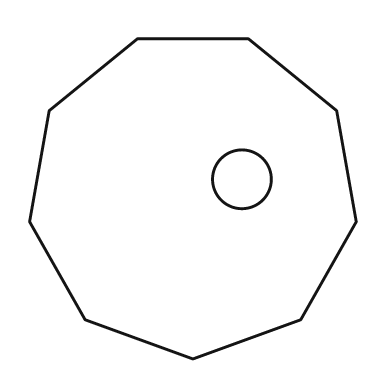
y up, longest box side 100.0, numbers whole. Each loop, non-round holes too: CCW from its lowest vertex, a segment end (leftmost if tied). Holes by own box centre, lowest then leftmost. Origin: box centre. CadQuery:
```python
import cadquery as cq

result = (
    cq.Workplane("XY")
    .moveTo(0.0, -49.0)
    .lineTo(33.0, -37.0)
    .lineTo(50.0, -7.0)
    .lineTo(44.0, 27.0)
    .lineTo(17.0, 49.0)
    .lineTo(-17.0, 49.0)
    .lineTo(-44.0, 27.0)
    .lineTo(-50.0, -7.0)
    .lineTo(-33.0, -37.0)
    .close()
    .moveTo(15.0, 6.0)
    .circle(9.0)
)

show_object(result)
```